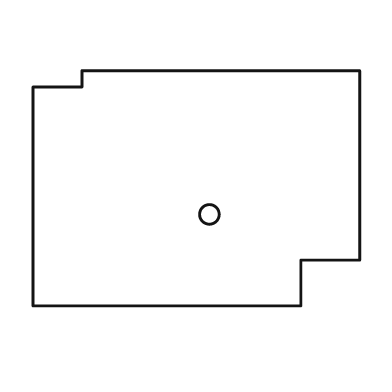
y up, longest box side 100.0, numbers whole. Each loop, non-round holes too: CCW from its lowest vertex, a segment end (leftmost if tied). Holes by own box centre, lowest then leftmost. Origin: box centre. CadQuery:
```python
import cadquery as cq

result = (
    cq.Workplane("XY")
    .moveTo(-50.0, -36.0)
    .lineTo(32.0, -36.0)
    .lineTo(32.0, -22.0)
    .lineTo(50.0, -22.0)
    .lineTo(50.0, 36.0)
    .lineTo(-35.0, 36.0)
    .lineTo(-35.0, 31.0)
    .lineTo(-50.0, 31.0)
    .close()
    .moveTo(4.0, -8.0)
    .circle(3.0)
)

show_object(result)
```